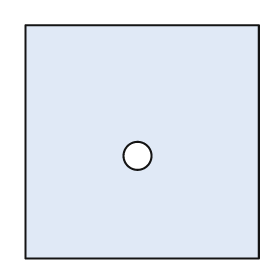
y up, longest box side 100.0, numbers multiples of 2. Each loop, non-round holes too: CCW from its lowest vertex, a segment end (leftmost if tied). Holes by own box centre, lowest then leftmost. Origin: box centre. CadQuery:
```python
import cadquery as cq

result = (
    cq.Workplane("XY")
    .moveTo(-50.0, -50.0)
    .lineTo(50.0, -50.0)
    .lineTo(50.0, 50.0)
    .lineTo(-50.0, 50.0)
    .close()
    .moveTo(-2.0, -6.0)
    .circle(6.0)
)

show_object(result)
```